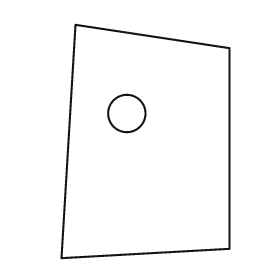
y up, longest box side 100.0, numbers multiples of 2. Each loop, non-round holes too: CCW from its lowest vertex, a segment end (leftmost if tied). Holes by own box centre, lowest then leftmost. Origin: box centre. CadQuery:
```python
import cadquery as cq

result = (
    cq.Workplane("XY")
    .moveTo(-36.0, -50.0)
    .lineTo(36.0, -46.0)
    .lineTo(36.0, 40.0)
    .lineTo(-30.0, 50.0)
    .close()
    .moveTo(-8.0, 12.0)
    .circle(8.0)
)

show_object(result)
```